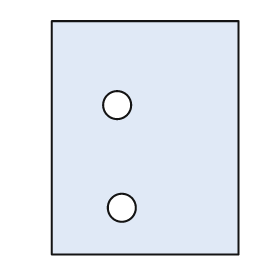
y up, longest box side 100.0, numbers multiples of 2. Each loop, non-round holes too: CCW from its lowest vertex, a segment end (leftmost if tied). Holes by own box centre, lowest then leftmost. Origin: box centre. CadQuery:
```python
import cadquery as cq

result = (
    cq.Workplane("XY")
    .moveTo(-40.0, -50.0)
    .lineTo(40.0, -50.0)
    .lineTo(40.0, 50.0)
    .lineTo(-40.0, 50.0)
    .close()
    .moveTo(-10.0, -30.0)
    .circle(6.0)
    .moveTo(-12.0, 14.0)
    .circle(6.0)
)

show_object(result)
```